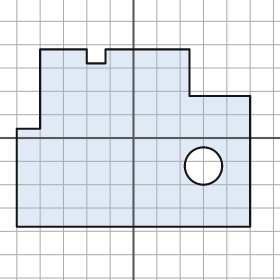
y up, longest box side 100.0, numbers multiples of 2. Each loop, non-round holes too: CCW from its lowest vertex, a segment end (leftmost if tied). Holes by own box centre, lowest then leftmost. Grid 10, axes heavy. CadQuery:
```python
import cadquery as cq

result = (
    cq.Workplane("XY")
    .moveTo(-50.0, -38.0)
    .lineTo(50.0, -38.0)
    .lineTo(50.0, 18.0)
    .lineTo(24.0, 18.0)
    .lineTo(24.0, 38.0)
    .lineTo(-12.0, 38.0)
    .lineTo(-12.0, 32.0)
    .lineTo(-20.0, 32.0)
    .lineTo(-20.0, 38.0)
    .lineTo(-40.0, 38.0)
    .lineTo(-40.0, 4.0)
    .lineTo(-50.0, 4.0)
    .close()
    .moveTo(30.0, -12.0)
    .circle(8.0)
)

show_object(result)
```